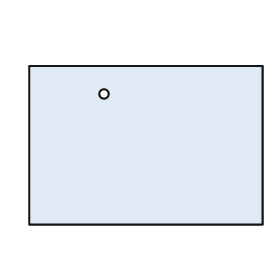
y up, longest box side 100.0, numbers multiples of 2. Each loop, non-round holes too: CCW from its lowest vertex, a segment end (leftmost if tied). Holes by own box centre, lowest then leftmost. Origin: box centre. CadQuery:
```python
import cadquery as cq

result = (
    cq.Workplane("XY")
    .moveTo(-50.0, -34.0)
    .lineTo(50.0, -34.0)
    .lineTo(50.0, 34.0)
    .lineTo(-50.0, 34.0)
    .close()
    .moveTo(-18.0, 22.0)
    .circle(2.0)
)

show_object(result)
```